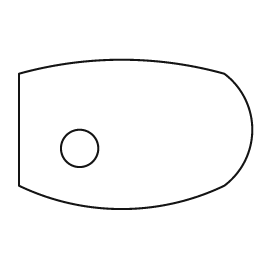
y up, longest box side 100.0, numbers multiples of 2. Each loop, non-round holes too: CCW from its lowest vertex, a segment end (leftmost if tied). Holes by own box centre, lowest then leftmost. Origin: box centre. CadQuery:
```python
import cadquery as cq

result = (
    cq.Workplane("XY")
    .moveTo(-50.0, -22.0)
    .threePointArc((-6.0, -32.0), (38.0, -22.0))
    .threePointArc((50.0, 2.0), (38.0, 26.0))
    .threePointArc((-6.0, 32.0), (-50.0, 26.0))
    .close()
    .moveTo(-24.0, -6.0)
    .circle(8.0)
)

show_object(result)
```